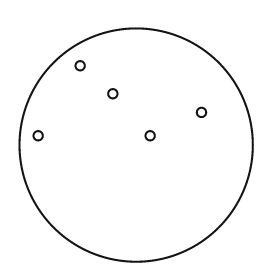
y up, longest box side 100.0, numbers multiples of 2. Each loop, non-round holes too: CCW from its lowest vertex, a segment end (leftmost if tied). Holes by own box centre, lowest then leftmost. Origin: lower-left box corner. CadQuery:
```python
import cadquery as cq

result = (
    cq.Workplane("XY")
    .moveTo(50.0, 50.0)
    .circle(50.0)
    .moveTo(8.0, 54.0)
    .circle(2.0)
    .moveTo(56.0, 54.0)
    .circle(2.0)
    .moveTo(78.0, 64.0)
    .circle(2.0)
    .moveTo(40.0, 72.0)
    .circle(2.0)
    .moveTo(26.0, 84.0)
    .circle(2.0)
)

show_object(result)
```